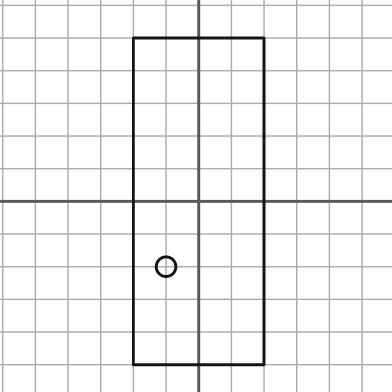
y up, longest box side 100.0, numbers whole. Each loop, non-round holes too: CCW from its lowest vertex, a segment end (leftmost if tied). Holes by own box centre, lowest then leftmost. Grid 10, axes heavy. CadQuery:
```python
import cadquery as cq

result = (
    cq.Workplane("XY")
    .moveTo(-20.0, -50.0)
    .lineTo(20.0, -50.0)
    .lineTo(20.0, 50.0)
    .lineTo(-20.0, 50.0)
    .close()
    .moveTo(-10.0, -20.0)
    .circle(3.0)
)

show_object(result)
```